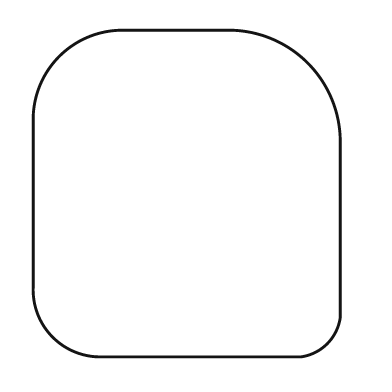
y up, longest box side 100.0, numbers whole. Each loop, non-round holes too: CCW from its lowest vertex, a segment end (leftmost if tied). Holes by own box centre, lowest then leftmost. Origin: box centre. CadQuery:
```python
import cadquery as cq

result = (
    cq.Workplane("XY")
    .moveTo(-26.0, -50.0)
    .lineTo(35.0, -50.0)
    .threePointArc((43.0, -46.0), (47.0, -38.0))
    .lineTo(47.0, 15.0)
    .threePointArc((37.0, 40.0), (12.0, 50.0))
    .lineTo(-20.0, 50.0)
    .threePointArc((-39.0, 42.0), (-47.0, 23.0))
    .lineTo(-47.0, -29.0)
    .threePointArc((-41.0, -44.0), (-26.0, -50.0))
    .close()
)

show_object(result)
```